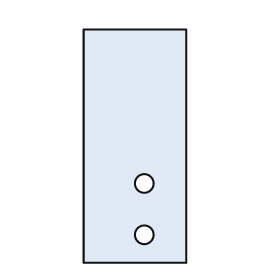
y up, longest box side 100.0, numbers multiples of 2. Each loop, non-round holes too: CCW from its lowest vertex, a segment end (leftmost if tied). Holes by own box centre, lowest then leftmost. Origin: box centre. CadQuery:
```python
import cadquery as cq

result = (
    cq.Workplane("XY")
    .moveTo(-22.0, -50.0)
    .lineTo(22.0, -50.0)
    .lineTo(22.0, 50.0)
    .lineTo(-22.0, 50.0)
    .close()
    .moveTo(4.0, -38.0)
    .circle(4.0)
    .moveTo(4.0, -16.0)
    .circle(4.0)
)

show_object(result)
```